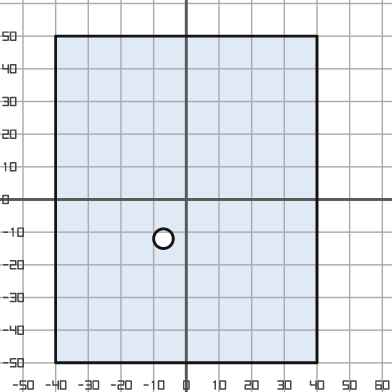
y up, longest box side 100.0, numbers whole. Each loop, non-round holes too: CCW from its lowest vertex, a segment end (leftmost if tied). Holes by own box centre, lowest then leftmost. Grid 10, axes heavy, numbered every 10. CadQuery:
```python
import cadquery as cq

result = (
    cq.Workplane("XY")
    .moveTo(-40.0, -50.0)
    .lineTo(40.0, -50.0)
    .lineTo(40.0, 50.0)
    .lineTo(-40.0, 50.0)
    .close()
    .moveTo(-7.0, -12.0)
    .circle(3.0)
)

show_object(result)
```